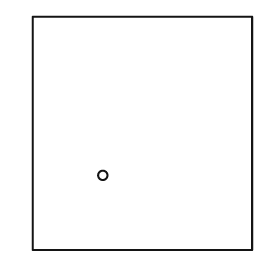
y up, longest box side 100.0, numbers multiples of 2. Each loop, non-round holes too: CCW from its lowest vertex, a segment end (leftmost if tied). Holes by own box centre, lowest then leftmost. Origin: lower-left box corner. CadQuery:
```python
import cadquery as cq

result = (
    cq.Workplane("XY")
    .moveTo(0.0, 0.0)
    .lineTo(94.0, 0.0)
    .lineTo(94.0, 100.0)
    .lineTo(0.0, 100.0)
    .close()
    .moveTo(30.0, 32.0)
    .circle(2.0)
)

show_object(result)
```